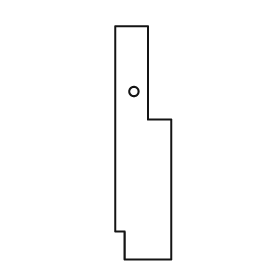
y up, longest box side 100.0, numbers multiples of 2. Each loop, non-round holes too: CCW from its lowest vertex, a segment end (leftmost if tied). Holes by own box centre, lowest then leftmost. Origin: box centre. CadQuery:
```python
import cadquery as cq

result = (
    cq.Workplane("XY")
    .moveTo(-8.0, -50.0)
    .lineTo(12.0, -50.0)
    .lineTo(12.0, 10.0)
    .lineTo(2.0, 10.0)
    .lineTo(2.0, 50.0)
    .lineTo(-12.0, 50.0)
    .lineTo(-12.0, -38.0)
    .lineTo(-8.0, -38.0)
    .close()
    .moveTo(-4.0, 22.0)
    .circle(2.0)
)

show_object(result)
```